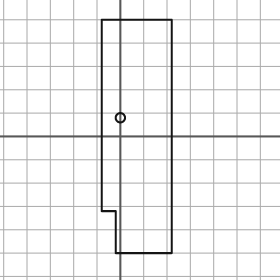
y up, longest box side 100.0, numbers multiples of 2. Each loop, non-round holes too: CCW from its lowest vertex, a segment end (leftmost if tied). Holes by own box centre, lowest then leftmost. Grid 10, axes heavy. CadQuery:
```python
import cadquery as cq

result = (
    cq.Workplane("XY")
    .moveTo(-2.0, -50.0)
    .lineTo(22.0, -50.0)
    .lineTo(22.0, 50.0)
    .lineTo(-8.0, 50.0)
    .lineTo(-8.0, -32.0)
    .lineTo(-2.0, -32.0)
    .close()
    .moveTo(0.0, 8.0)
    .circle(2.0)
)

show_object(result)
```